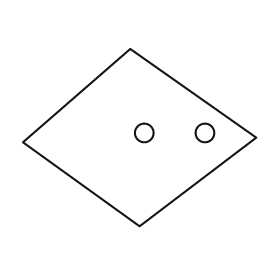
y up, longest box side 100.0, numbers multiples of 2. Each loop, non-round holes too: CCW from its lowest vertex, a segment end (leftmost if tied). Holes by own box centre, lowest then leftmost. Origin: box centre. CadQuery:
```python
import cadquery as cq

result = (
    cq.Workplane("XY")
    .moveTo(0.0, -38.0)
    .lineTo(50.0, 0.0)
    .lineTo(-4.0, 38.0)
    .lineTo(-50.0, -2.0)
    .close()
    .moveTo(2.0, 2.0)
    .circle(4.0)
    .moveTo(28.0, 2.0)
    .circle(4.0)
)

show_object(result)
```